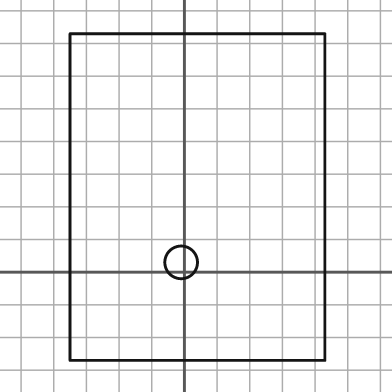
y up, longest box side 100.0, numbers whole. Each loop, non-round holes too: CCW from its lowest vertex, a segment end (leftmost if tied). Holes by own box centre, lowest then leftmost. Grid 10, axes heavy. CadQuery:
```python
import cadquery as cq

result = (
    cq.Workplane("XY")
    .moveTo(-35.0, -27.0)
    .lineTo(43.0, -27.0)
    .lineTo(43.0, 73.0)
    .lineTo(-35.0, 73.0)
    .close()
    .moveTo(-1.0, 3.0)
    .circle(5.0)
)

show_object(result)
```